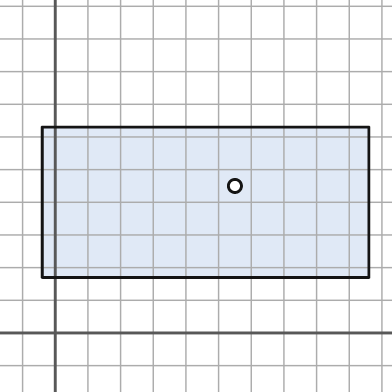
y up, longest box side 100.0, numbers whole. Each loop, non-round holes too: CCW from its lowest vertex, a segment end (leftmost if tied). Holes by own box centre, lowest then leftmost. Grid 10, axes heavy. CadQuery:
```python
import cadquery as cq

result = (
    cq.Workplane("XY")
    .moveTo(-4.0, 17.0)
    .lineTo(96.0, 17.0)
    .lineTo(96.0, 63.0)
    .lineTo(-4.0, 63.0)
    .close()
    .moveTo(55.0, 45.0)
    .circle(2.0)
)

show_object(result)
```